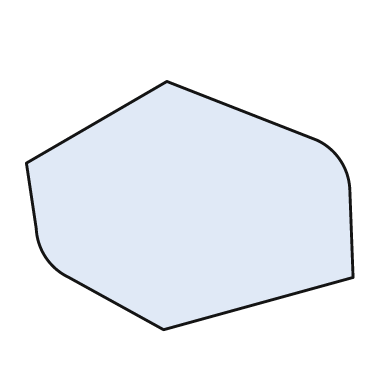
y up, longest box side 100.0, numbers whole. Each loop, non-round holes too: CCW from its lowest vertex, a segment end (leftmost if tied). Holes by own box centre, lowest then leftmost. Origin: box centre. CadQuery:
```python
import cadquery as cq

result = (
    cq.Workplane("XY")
    .moveTo(-8.0, -38.0)
    .lineTo(50.0, -22.0)
    .lineTo(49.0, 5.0)
    .threePointArc((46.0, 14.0), (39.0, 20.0))
    .lineTo(-7.0, 38.0)
    .lineTo(-50.0, 13.0)
    .lineTo(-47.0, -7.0)
    .threePointArc((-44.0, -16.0), (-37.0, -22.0))
    .close()
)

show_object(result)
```